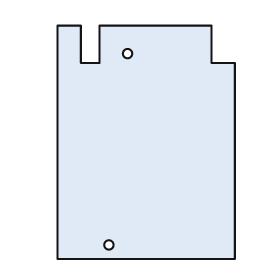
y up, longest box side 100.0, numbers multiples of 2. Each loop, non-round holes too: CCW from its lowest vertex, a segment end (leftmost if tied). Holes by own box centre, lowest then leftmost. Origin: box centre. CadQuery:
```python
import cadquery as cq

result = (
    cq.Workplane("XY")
    .moveTo(-38.0, -50.0)
    .lineTo(38.0, -50.0)
    .lineTo(38.0, 34.0)
    .lineTo(28.0, 34.0)
    .lineTo(28.0, 50.0)
    .lineTo(-20.0, 50.0)
    .lineTo(-20.0, 34.0)
    .lineTo(-28.0, 34.0)
    .lineTo(-28.0, 50.0)
    .lineTo(-38.0, 50.0)
    .close()
    .moveTo(-16.0, -44.0)
    .circle(2.0)
    .moveTo(-8.0, 38.0)
    .circle(2.0)
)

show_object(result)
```